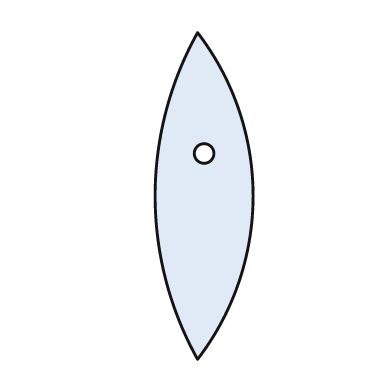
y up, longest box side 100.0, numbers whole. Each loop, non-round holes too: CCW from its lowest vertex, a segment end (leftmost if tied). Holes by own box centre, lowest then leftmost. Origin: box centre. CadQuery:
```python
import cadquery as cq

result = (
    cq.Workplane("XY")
    .moveTo(-2.0, -50.0)
    .threePointArc((15.0, 0.0), (-2.0, 50.0))
    .threePointArc((-15.0, 0.0), (-2.0, -50.0))
    .close()
    .moveTo(0.0, 13.0)
    .circle(3.0)
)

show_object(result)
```